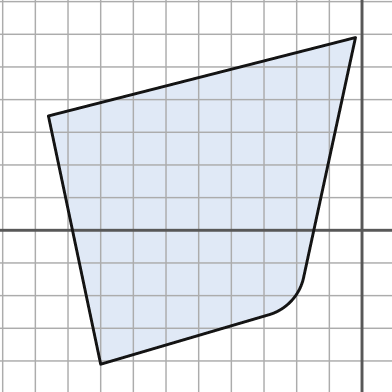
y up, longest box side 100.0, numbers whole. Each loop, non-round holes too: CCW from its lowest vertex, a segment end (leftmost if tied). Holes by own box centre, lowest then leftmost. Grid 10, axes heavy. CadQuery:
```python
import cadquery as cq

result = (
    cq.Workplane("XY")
    .moveTo(-80.0, -41.0)
    .lineTo(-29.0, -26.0)
    .threePointArc((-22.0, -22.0), (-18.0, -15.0))
    .lineTo(-2.0, 59.0)
    .lineTo(-96.0, 35.0)
    .close()
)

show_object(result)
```